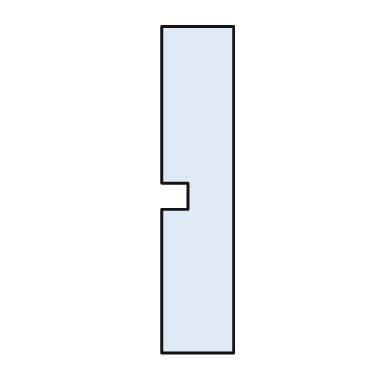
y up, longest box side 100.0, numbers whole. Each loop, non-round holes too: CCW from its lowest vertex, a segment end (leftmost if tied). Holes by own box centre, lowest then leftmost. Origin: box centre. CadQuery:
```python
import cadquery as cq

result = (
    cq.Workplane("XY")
    .moveTo(-11.0, -50.0)
    .lineTo(11.0, -50.0)
    .lineTo(11.0, 50.0)
    .lineTo(-11.0, 50.0)
    .lineTo(-11.0, 2.0)
    .lineTo(-3.0, 2.0)
    .lineTo(-3.0, -6.0)
    .lineTo(-11.0, -6.0)
    .close()
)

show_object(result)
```